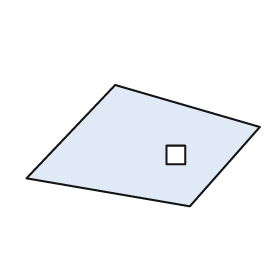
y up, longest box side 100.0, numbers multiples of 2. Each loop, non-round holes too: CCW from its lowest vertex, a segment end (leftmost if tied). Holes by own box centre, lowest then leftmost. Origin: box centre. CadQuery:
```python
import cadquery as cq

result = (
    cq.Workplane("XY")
    .moveTo(20.0, -26.0)
    .lineTo(50.0, 8.0)
    .lineTo(-12.0, 26.0)
    .lineTo(-50.0, -14.0)
    .close()
    .moveTo(10.0, -8.0)
    .lineTo(18.0, -8.0)
    .lineTo(18.0, 0.0)
    .lineTo(10.0, 0.0)
    .close()
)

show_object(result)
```